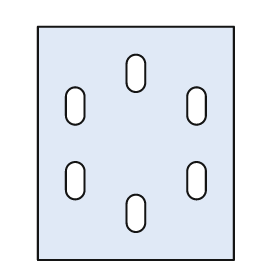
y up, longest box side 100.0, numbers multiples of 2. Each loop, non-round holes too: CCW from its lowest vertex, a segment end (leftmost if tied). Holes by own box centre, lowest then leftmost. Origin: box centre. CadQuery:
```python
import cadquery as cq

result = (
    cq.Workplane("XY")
    .moveTo(-42.0, -50.0)
    .lineTo(42.0, -50.0)
    .lineTo(42.0, 50.0)
    .lineTo(-42.0, 50.0)
    .close()
    .moveTo(-4.0, -34.0)
    .threePointArc((0.0, -38.0), (4.0, -34.0))
    .lineTo(4.0, -26.0)
    .threePointArc((0.0, -22.0), (-4.0, -26.0))
    .close()
    .moveTo(-30.0, -20.0)
    .threePointArc((-26.0, -24.0), (-22.0, -20.0))
    .lineTo(-22.0, -12.0)
    .threePointArc((-26.0, -8.0), (-30.0, -12.0))
    .close()
    .moveTo(22.0, -20.0)
    .threePointArc((26.0, -24.0), (30.0, -20.0))
    .lineTo(30.0, -12.0)
    .threePointArc((26.0, -8.0), (22.0, -12.0))
    .close()
    .moveTo(-30.0, 12.0)
    .threePointArc((-26.0, 8.0), (-22.0, 12.0))
    .lineTo(-22.0, 20.0)
    .threePointArc((-26.0, 24.0), (-30.0, 20.0))
    .close()
    .moveTo(22.0, 12.0)
    .threePointArc((26.0, 8.0), (30.0, 12.0))
    .lineTo(30.0, 20.0)
    .threePointArc((26.0, 24.0), (22.0, 20.0))
    .close()
    .moveTo(-4.0, 26.0)
    .threePointArc((0.0, 22.0), (4.0, 26.0))
    .lineTo(4.0, 34.0)
    .threePointArc((0.0, 38.0), (-4.0, 34.0))
    .close()
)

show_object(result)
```